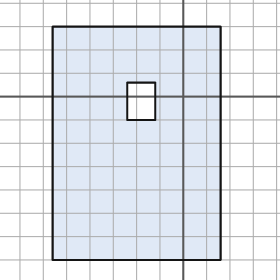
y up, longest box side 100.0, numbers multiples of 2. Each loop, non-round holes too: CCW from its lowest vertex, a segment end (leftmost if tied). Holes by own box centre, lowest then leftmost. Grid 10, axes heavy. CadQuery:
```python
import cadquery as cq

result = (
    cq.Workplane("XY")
    .moveTo(-56.0, -70.0)
    .lineTo(16.0, -70.0)
    .lineTo(16.0, 30.0)
    .lineTo(-56.0, 30.0)
    .close()
    .moveTo(-24.0, -10.0)
    .lineTo(-12.0, -10.0)
    .lineTo(-12.0, 6.0)
    .lineTo(-24.0, 6.0)
    .close()
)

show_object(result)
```